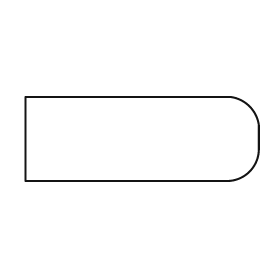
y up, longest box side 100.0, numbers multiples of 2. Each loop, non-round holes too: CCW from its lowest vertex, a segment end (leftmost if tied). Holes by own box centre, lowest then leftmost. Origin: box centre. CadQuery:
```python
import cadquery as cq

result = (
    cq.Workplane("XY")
    .moveTo(-50.0, -18.0)
    .lineTo(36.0, -18.0)
    .threePointArc((46.0, -14.0), (50.0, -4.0))
    .lineTo(50.0, 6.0)
    .threePointArc((46.0, 14.0), (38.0, 18.0))
    .lineTo(-50.0, 18.0)
    .close()
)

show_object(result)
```